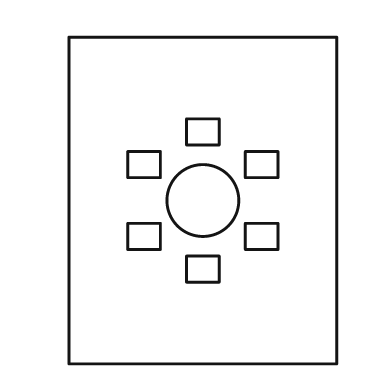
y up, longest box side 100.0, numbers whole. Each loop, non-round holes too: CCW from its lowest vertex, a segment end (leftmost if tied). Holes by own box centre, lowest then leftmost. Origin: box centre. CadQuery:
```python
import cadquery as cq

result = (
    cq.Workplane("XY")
    .moveTo(-41.0, -50.0)
    .lineTo(41.0, -50.0)
    .lineTo(41.0, 50.0)
    .lineTo(-41.0, 50.0)
    .close()
    .moveTo(-5.0, -25.0)
    .lineTo(5.0, -25.0)
    .lineTo(5.0, -17.0)
    .lineTo(-5.0, -17.0)
    .close()
    .moveTo(-23.0, -15.0)
    .lineTo(-13.0, -15.0)
    .lineTo(-13.0, -7.0)
    .lineTo(-23.0, -7.0)
    .close()
    .moveTo(13.0, -15.0)
    .lineTo(23.0, -15.0)
    .lineTo(23.0, -7.0)
    .lineTo(13.0, -7.0)
    .close()
    .moveTo(0.0, 0.0)
    .circle(11.0)
    .moveTo(-23.0, 7.0)
    .lineTo(-13.0, 7.0)
    .lineTo(-13.0, 15.0)
    .lineTo(-23.0, 15.0)
    .close()
    .moveTo(13.0, 7.0)
    .lineTo(23.0, 7.0)
    .lineTo(23.0, 15.0)
    .lineTo(13.0, 15.0)
    .close()
    .moveTo(-5.0, 17.0)
    .lineTo(5.0, 17.0)
    .lineTo(5.0, 25.0)
    .lineTo(-5.0, 25.0)
    .close()
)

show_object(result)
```